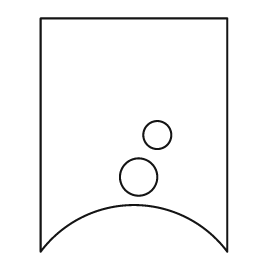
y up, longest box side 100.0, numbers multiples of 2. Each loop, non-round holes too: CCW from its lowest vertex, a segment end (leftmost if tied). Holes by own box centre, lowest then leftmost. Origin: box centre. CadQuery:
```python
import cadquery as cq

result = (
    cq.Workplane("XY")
    .moveTo(-40.0, -50.0)
    .threePointArc((0.0, -30.0), (40.0, -50.0))
    .lineTo(40.0, 50.0)
    .lineTo(-40.0, 50.0)
    .close()
    .moveTo(2.0, -18.0)
    .circle(8.0)
    .moveTo(10.0, 0.0)
    .circle(6.0)
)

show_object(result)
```